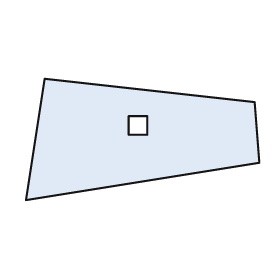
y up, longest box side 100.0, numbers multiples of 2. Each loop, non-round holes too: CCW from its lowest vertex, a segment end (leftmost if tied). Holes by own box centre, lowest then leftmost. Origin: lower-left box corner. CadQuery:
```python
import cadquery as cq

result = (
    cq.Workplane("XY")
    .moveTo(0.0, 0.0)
    .lineTo(100.0, 16.0)
    .lineTo(98.0, 42.0)
    .lineTo(8.0, 52.0)
    .close()
    .moveTo(44.0, 28.0)
    .lineTo(52.0, 28.0)
    .lineTo(52.0, 36.0)
    .lineTo(44.0, 36.0)
    .close()
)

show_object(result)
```